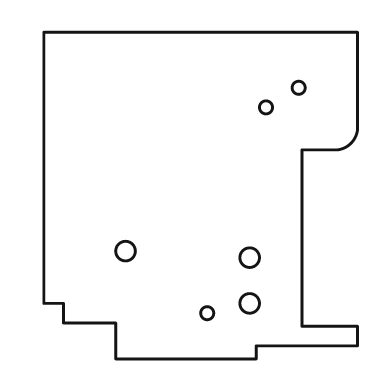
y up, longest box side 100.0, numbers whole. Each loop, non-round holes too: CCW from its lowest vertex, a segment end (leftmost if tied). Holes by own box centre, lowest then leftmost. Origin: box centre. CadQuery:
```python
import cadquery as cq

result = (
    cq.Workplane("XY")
    .moveTo(-26.0, -50.0)
    .lineTo(17.0, -50.0)
    .lineTo(17.0, -46.0)
    .lineTo(48.0, -46.0)
    .lineTo(48.0, -40.0)
    .lineTo(31.0, -40.0)
    .lineTo(31.0, 14.0)
    .lineTo(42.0, 14.0)
    .threePointArc((46.0, 16.0), (48.0, 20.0))
    .lineTo(48.0, 50.0)
    .lineTo(-48.0, 50.0)
    .lineTo(-48.0, -33.0)
    .lineTo(-42.0, -33.0)
    .lineTo(-42.0, -39.0)
    .lineTo(-26.0, -39.0)
    .close()
    .moveTo(2.0, -36.0)
    .circle(2.0)
    .moveTo(15.0, -33.0)
    .circle(3.0)
    .moveTo(15.0, -19.0)
    .circle(3.0)
    .moveTo(-23.0, -17.0)
    .circle(3.0)
    .moveTo(20.0, 27.0)
    .circle(2.0)
    .moveTo(30.0, 33.0)
    .circle(2.0)
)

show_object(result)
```